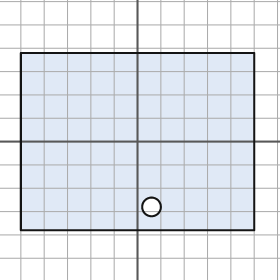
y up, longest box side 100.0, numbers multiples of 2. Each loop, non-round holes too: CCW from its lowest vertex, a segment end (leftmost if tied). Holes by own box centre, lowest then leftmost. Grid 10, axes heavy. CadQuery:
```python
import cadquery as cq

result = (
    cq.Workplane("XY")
    .moveTo(-50.0, -38.0)
    .lineTo(50.0, -38.0)
    .lineTo(50.0, 38.0)
    .lineTo(-50.0, 38.0)
    .close()
    .moveTo(6.0, -28.0)
    .circle(4.0)
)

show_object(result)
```